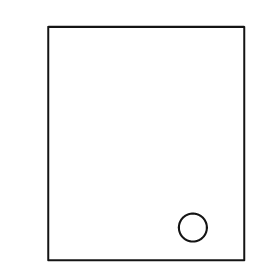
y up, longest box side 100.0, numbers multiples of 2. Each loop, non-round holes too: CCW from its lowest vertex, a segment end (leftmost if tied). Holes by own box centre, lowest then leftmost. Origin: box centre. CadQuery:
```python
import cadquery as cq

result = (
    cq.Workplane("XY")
    .moveTo(-42.0, -50.0)
    .lineTo(42.0, -50.0)
    .lineTo(42.0, 50.0)
    .lineTo(-42.0, 50.0)
    .close()
    .moveTo(20.0, -36.0)
    .circle(6.0)
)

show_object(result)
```